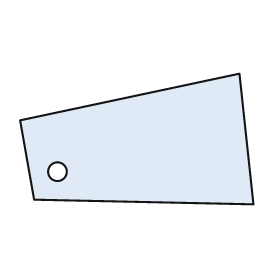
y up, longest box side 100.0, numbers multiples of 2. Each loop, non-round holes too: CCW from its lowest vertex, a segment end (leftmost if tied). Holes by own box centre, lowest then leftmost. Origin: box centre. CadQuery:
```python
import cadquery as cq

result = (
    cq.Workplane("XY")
    .moveTo(50.0, -28.0)
    .lineTo(44.0, 28.0)
    .lineTo(-50.0, 8.0)
    .lineTo(-44.0, -26.0)
    .close()
    .moveTo(-34.0, -14.0)
    .circle(4.0)
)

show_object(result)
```